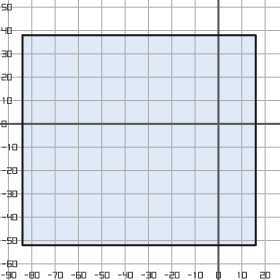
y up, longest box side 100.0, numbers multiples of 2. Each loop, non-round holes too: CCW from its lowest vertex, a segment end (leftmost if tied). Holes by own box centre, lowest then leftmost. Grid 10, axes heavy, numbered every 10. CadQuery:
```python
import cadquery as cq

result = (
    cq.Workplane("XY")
    .moveTo(-84.0, -52.0)
    .lineTo(16.0, -52.0)
    .lineTo(16.0, 38.0)
    .lineTo(-84.0, 38.0)
    .close()
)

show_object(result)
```